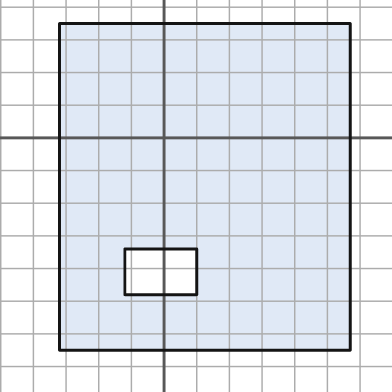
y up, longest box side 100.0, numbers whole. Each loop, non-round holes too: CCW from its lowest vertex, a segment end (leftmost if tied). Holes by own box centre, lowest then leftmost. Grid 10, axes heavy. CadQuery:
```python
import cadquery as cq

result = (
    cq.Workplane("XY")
    .moveTo(-32.0, -65.0)
    .lineTo(57.0, -65.0)
    .lineTo(57.0, 35.0)
    .lineTo(-32.0, 35.0)
    .close()
    .moveTo(-12.0, -48.0)
    .lineTo(10.0, -48.0)
    .lineTo(10.0, -34.0)
    .lineTo(-12.0, -34.0)
    .close()
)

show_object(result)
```